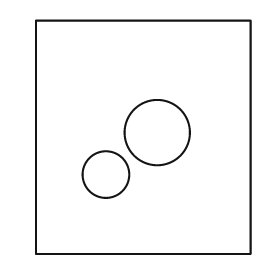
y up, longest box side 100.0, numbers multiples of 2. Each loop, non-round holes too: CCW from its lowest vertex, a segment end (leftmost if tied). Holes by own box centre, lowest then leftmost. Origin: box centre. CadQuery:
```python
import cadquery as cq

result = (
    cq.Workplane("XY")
    .moveTo(-46.0, -50.0)
    .lineTo(46.0, -50.0)
    .lineTo(46.0, 50.0)
    .lineTo(-46.0, 50.0)
    .close()
    .moveTo(-16.0, -16.0)
    .circle(10.0)
    .moveTo(6.0, 2.0)
    .circle(14.0)
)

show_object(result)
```